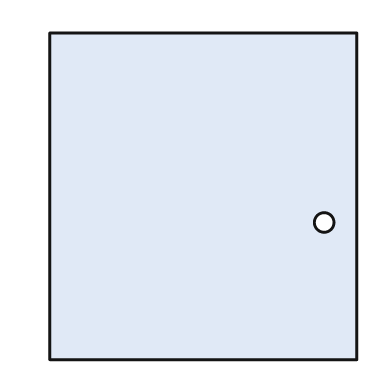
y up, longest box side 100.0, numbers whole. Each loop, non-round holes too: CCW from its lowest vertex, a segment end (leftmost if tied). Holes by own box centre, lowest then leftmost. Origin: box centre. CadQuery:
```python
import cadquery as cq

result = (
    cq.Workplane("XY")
    .moveTo(-47.0, -50.0)
    .lineTo(47.0, -50.0)
    .lineTo(47.0, 50.0)
    .lineTo(-47.0, 50.0)
    .close()
    .moveTo(37.0, -8.0)
    .circle(3.0)
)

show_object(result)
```